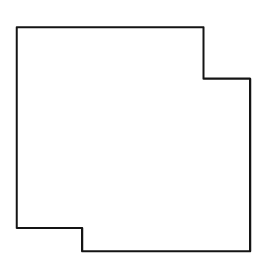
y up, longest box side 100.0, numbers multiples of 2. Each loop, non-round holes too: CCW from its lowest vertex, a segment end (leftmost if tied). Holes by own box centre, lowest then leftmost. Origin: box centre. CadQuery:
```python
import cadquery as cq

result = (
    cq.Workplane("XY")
    .moveTo(-22.0, -48.0)
    .lineTo(50.0, -48.0)
    .lineTo(50.0, 26.0)
    .lineTo(30.0, 26.0)
    .lineTo(30.0, 48.0)
    .lineTo(-50.0, 48.0)
    .lineTo(-50.0, -38.0)
    .lineTo(-22.0, -38.0)
    .close()
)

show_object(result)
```